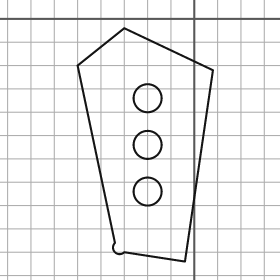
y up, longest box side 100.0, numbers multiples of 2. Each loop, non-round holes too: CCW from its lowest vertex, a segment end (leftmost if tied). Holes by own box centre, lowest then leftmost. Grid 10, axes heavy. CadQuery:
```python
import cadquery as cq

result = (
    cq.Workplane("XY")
    .moveTo(-4.0, -104.0)
    .lineTo(8.0, -22.0)
    .lineTo(-30.0, -4.0)
    .lineTo(-50.0, -20.0)
    .lineTo(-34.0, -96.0)
    .threePointArc((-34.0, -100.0), (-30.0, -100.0))
    .close()
    .moveTo(-20.0, -74.0)
    .circle(6.0)
    .moveTo(-20.0, -54.0)
    .circle(6.0)
    .moveTo(-20.0, -34.0)
    .circle(6.0)
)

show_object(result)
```